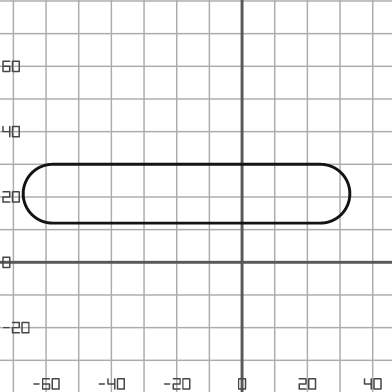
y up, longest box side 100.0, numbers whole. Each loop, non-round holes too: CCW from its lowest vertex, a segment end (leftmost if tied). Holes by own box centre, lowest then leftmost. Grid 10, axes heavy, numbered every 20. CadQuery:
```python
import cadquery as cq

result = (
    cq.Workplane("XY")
    .moveTo(-58.0, 12.0)
    .lineTo(24.0, 12.0)
    .threePointArc((33.0, 21.0), (24.0, 30.0))
    .lineTo(-58.0, 30.0)
    .threePointArc((-67.0, 21.0), (-58.0, 12.0))
    .close()
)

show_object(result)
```